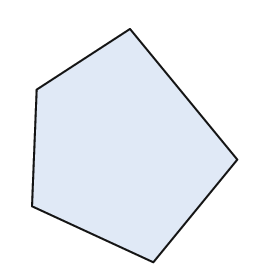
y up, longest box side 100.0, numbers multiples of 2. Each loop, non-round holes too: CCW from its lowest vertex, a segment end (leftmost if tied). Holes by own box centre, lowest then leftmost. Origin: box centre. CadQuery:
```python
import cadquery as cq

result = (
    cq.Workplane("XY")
    .moveTo(8.0, -50.0)
    .lineTo(44.0, -6.0)
    .lineTo(-2.0, 50.0)
    .lineTo(-42.0, 24.0)
    .lineTo(-44.0, -26.0)
    .close()
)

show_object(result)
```